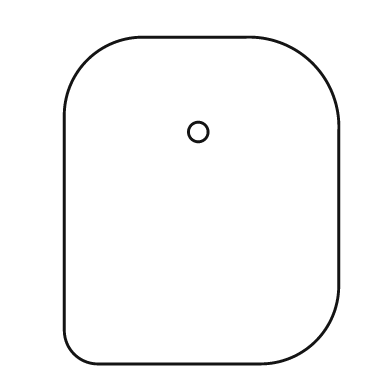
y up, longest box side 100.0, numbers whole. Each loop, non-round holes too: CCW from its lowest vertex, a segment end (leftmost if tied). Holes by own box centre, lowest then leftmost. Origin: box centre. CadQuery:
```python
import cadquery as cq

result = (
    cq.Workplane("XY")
    .moveTo(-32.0, -50.0)
    .lineTo(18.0, -50.0)
    .threePointArc((35.0, -43.0), (42.0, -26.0))
    .lineTo(42.0, 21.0)
    .threePointArc((34.0, 42.0), (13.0, 50.0))
    .lineTo(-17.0, 50.0)
    .threePointArc((-35.0, 43.0), (-42.0, 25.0))
    .lineTo(-42.0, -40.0)
    .threePointArc((-39.0, -47.0), (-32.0, -50.0))
    .close()
    .moveTo(-1.0, 21.0)
    .circle(3.0)
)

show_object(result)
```